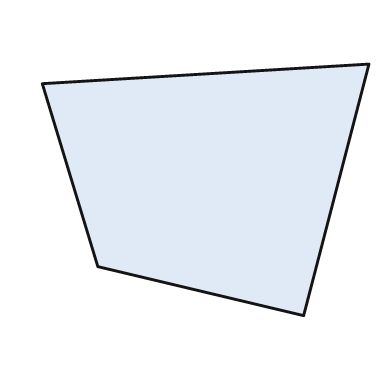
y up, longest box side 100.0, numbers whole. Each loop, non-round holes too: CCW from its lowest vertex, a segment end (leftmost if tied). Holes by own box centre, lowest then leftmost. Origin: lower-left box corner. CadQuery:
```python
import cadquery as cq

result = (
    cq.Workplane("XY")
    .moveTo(80.0, 0.0)
    .lineTo(100.0, 77.0)
    .lineTo(0.0, 71.0)
    .lineTo(17.0, 15.0)
    .close()
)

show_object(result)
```